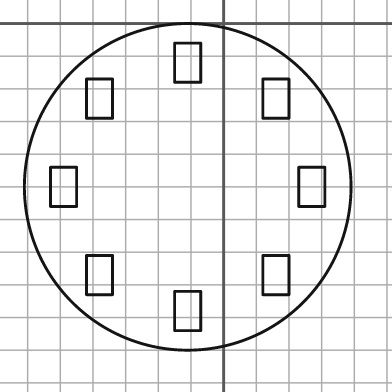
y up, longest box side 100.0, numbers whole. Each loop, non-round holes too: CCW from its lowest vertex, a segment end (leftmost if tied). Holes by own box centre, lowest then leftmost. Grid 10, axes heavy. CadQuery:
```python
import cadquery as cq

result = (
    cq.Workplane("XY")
    .moveTo(-11.0, -50.0)
    .circle(50.0)
    .moveTo(-15.0, -94.0)
    .lineTo(-7.0, -94.0)
    .lineTo(-7.0, -82.0)
    .lineTo(-15.0, -82.0)
    .close()
    .moveTo(-42.0, -83.0)
    .lineTo(-34.0, -83.0)
    .lineTo(-34.0, -71.0)
    .lineTo(-42.0, -71.0)
    .close()
    .moveTo(12.0, -83.0)
    .lineTo(20.0, -83.0)
    .lineTo(20.0, -71.0)
    .lineTo(12.0, -71.0)
    .close()
    .moveTo(-53.0, -56.0)
    .lineTo(-45.0, -56.0)
    .lineTo(-45.0, -44.0)
    .lineTo(-53.0, -44.0)
    .close()
    .moveTo(23.0, -56.0)
    .lineTo(31.0, -56.0)
    .lineTo(31.0, -44.0)
    .lineTo(23.0, -44.0)
    .close()
    .moveTo(-42.0, -29.0)
    .lineTo(-34.0, -29.0)
    .lineTo(-34.0, -17.0)
    .lineTo(-42.0, -17.0)
    .close()
    .moveTo(12.0, -29.0)
    .lineTo(20.0, -29.0)
    .lineTo(20.0, -17.0)
    .lineTo(12.0, -17.0)
    .close()
    .moveTo(-15.0, -18.0)
    .lineTo(-7.0, -18.0)
    .lineTo(-7.0, -6.0)
    .lineTo(-15.0, -6.0)
    .close()
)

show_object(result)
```